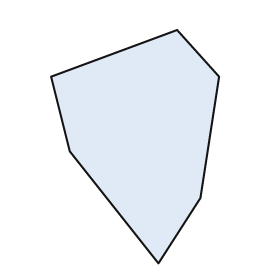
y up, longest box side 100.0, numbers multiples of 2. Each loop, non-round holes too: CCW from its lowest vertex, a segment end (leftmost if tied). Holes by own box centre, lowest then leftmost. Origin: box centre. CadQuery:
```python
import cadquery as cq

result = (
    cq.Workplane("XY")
    .moveTo(10.0, -50.0)
    .lineTo(28.0, -22.0)
    .lineTo(36.0, 30.0)
    .lineTo(18.0, 50.0)
    .lineTo(-36.0, 30.0)
    .lineTo(-28.0, -2.0)
    .close()
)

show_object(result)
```